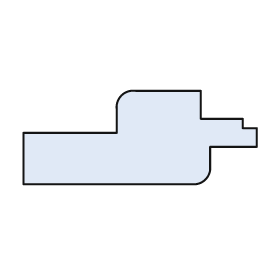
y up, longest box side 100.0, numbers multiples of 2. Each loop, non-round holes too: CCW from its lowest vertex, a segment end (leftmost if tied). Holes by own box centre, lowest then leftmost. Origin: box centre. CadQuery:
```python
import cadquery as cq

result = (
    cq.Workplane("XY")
    .moveTo(-50.0, -20.0)
    .lineTo(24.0, -20.0)
    .threePointArc((28.0, -18.0), (30.0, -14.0))
    .lineTo(30.0, -4.0)
    .lineTo(50.0, -4.0)
    .lineTo(50.0, 4.0)
    .lineTo(44.0, 4.0)
    .lineTo(44.0, 8.0)
    .lineTo(26.0, 8.0)
    .lineTo(26.0, 20.0)
    .lineTo(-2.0, 20.0)
    .threePointArc((-8.0, 18.0), (-10.0, 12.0))
    .lineTo(-10.0, 2.0)
    .lineTo(-50.0, 2.0)
    .close()
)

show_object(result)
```